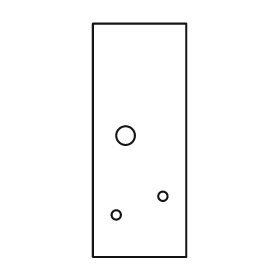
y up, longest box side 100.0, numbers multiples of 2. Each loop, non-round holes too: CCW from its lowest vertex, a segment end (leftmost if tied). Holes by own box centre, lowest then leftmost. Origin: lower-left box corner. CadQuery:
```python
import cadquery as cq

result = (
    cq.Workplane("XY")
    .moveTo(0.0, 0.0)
    .lineTo(40.0, 0.0)
    .lineTo(40.0, 100.0)
    .lineTo(0.0, 100.0)
    .close()
    .moveTo(10.0, 18.0)
    .circle(2.0)
    .moveTo(30.0, 26.0)
    .circle(2.0)
    .moveTo(14.0, 52.0)
    .circle(4.0)
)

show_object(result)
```